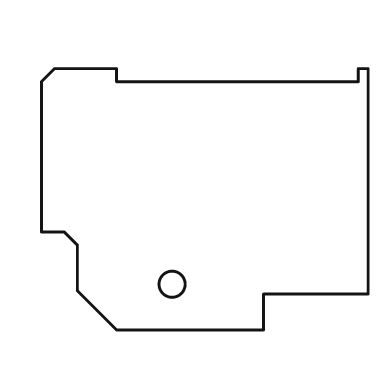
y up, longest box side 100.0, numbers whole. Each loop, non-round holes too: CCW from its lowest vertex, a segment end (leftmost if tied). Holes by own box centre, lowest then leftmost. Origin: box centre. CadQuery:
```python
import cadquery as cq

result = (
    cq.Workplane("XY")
    .moveTo(-27.0, -40.0)
    .lineTo(18.0, -40.0)
    .lineTo(18.0, -29.0)
    .lineTo(50.0, -29.0)
    .lineTo(50.0, 40.0)
    .lineTo(47.0, 40.0)
    .lineTo(47.0, 36.0)
    .lineTo(-27.0, 36.0)
    .lineTo(-27.0, 40.0)
    .lineTo(-46.0, 40.0)
    .lineTo(-50.0, 36.0)
    .lineTo(-50.0, -10.0)
    .lineTo(-43.0, -10.0)
    .lineTo(-39.0, -14.0)
    .lineTo(-39.0, -28.0)
    .close()
    .moveTo(-10.0, -26.0)
    .circle(4.0)
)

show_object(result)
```